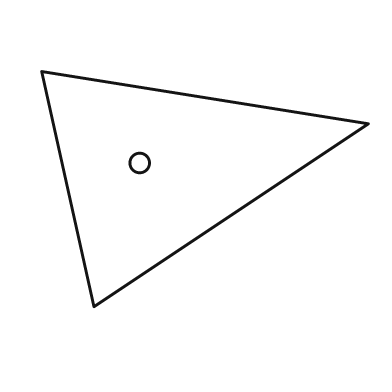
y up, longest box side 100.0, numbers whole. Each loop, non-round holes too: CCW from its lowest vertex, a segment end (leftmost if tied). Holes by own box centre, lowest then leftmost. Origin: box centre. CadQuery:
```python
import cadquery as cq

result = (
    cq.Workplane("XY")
    .moveTo(-34.0, -36.0)
    .lineTo(50.0, 20.0)
    .lineTo(-50.0, 36.0)
    .close()
    .moveTo(-20.0, 8.0)
    .circle(3.0)
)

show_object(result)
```